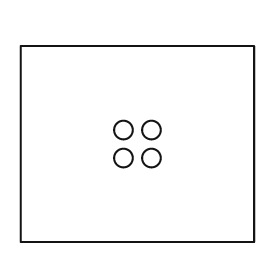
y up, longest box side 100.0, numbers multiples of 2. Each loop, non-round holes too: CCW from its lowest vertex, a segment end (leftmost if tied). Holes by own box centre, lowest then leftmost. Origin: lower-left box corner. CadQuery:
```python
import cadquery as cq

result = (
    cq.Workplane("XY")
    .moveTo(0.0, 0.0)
    .lineTo(100.0, 0.0)
    .lineTo(100.0, 84.0)
    .lineTo(0.0, 84.0)
    .close()
    .moveTo(44.0, 36.0)
    .circle(4.0)
    .moveTo(56.0, 36.0)
    .circle(4.0)
    .moveTo(44.0, 48.0)
    .circle(4.0)
    .moveTo(56.0, 48.0)
    .circle(4.0)
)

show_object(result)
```